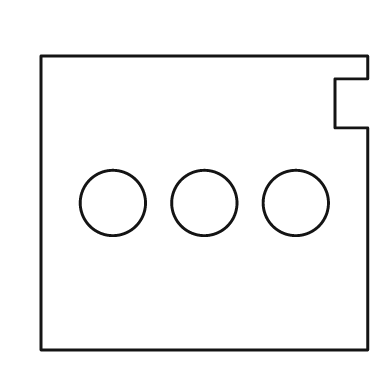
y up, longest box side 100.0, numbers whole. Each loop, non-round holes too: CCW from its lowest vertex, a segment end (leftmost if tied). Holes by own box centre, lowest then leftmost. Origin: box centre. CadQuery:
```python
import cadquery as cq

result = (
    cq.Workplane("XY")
    .moveTo(-50.0, -45.0)
    .lineTo(50.0, -45.0)
    .lineTo(50.0, 23.0)
    .lineTo(40.0, 23.0)
    .lineTo(40.0, 38.0)
    .lineTo(50.0, 38.0)
    .lineTo(50.0, 45.0)
    .lineTo(-50.0, 45.0)
    .close()
    .moveTo(-28.0, 0.0)
    .circle(10.0)
    .moveTo(0.0, 0.0)
    .circle(10.0)
    .moveTo(28.0, 0.0)
    .circle(10.0)
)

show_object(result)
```